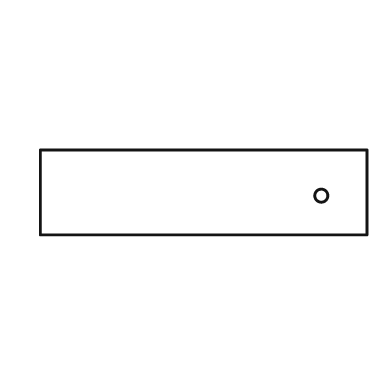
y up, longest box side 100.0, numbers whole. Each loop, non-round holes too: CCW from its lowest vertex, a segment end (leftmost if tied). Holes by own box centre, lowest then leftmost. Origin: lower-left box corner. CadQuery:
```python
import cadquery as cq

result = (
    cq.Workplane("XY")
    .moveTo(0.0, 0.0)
    .lineTo(100.0, 0.0)
    .lineTo(100.0, 26.0)
    .lineTo(0.0, 26.0)
    .close()
    .moveTo(86.0, 12.0)
    .circle(2.0)
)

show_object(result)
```